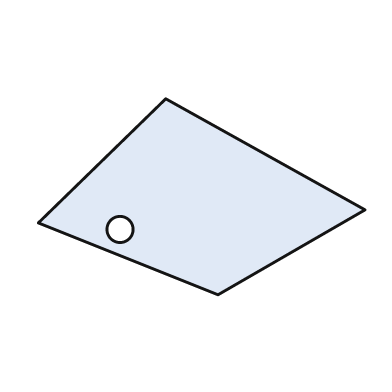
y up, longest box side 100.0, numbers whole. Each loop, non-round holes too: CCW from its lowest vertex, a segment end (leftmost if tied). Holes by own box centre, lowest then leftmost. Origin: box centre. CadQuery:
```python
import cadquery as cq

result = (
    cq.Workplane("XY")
    .moveTo(5.0, -30.0)
    .lineTo(50.0, -4.0)
    .lineTo(-11.0, 30.0)
    .lineTo(-50.0, -8.0)
    .close()
    .moveTo(-25.0, -10.0)
    .circle(4.0)
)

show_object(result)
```